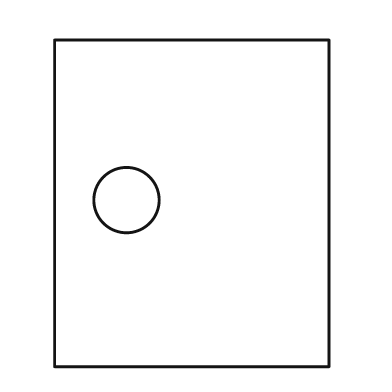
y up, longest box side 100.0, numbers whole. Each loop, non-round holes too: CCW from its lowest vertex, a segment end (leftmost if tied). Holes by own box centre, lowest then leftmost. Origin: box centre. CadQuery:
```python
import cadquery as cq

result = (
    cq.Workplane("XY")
    .moveTo(-42.0, -50.0)
    .lineTo(42.0, -50.0)
    .lineTo(42.0, 50.0)
    .lineTo(-42.0, 50.0)
    .close()
    .moveTo(-20.0, 1.0)
    .circle(10.0)
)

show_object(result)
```